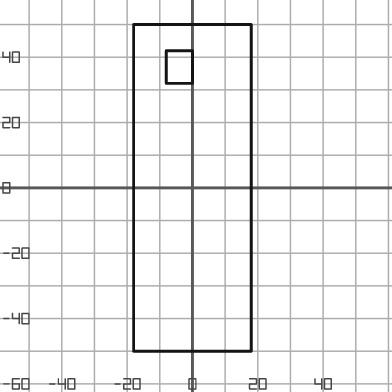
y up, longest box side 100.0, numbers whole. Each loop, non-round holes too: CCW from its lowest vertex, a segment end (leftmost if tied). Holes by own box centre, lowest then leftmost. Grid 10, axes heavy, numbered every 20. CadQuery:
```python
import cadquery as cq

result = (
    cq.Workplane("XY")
    .moveTo(-18.0, -50.0)
    .lineTo(18.0, -50.0)
    .lineTo(18.0, 50.0)
    .lineTo(-18.0, 50.0)
    .close()
    .moveTo(-8.0, 32.0)
    .lineTo(0.0, 32.0)
    .lineTo(0.0, 42.0)
    .lineTo(-8.0, 42.0)
    .close()
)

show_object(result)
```